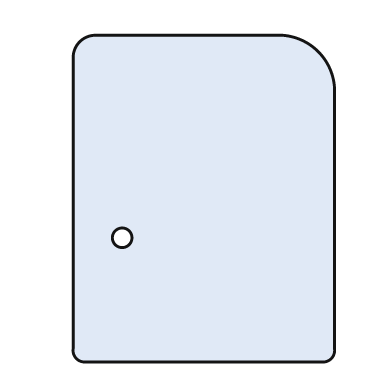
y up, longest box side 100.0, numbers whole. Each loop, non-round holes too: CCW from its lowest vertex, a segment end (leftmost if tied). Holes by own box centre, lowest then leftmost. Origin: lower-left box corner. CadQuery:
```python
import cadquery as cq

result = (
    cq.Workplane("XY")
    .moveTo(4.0, 0.0)
    .lineTo(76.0, 0.0)
    .threePointArc((79.0, 1.0), (80.0, 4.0))
    .lineTo(80.0, 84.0)
    .threePointArc((75.0, 95.0), (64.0, 100.0))
    .lineTo(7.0, 100.0)
    .threePointArc((2.0, 98.0), (0.0, 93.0))
    .lineTo(0.0, 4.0)
    .threePointArc((1.0, 1.0), (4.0, 0.0))
    .close()
    .moveTo(15.0, 38.0)
    .circle(3.0)
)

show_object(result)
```